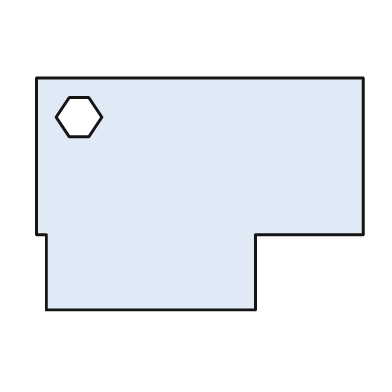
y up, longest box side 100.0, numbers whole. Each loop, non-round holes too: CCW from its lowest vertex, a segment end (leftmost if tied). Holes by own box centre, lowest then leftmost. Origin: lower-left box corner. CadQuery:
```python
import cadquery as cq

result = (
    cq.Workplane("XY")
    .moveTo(3.0, 0.0)
    .lineTo(67.0, 0.0)
    .lineTo(67.0, 23.0)
    .lineTo(100.0, 23.0)
    .lineTo(100.0, 71.0)
    .lineTo(0.0, 71.0)
    .lineTo(0.0, 23.0)
    .lineTo(3.0, 23.0)
    .close()
    .moveTo(10.0, 53.0)
    .lineTo(16.0, 53.0)
    .lineTo(20.0, 59.0)
    .lineTo(16.0, 65.0)
    .lineTo(10.0, 65.0)
    .lineTo(6.0, 59.0)
    .close()
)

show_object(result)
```